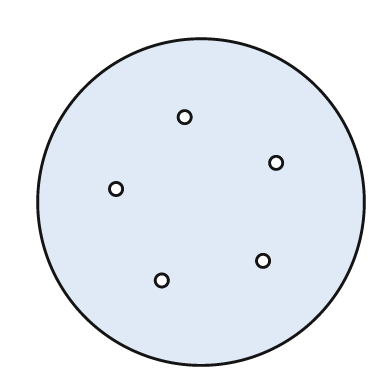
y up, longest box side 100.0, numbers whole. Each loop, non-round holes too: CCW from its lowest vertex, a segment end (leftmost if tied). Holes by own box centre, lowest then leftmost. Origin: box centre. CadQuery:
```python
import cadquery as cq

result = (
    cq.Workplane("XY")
    .moveTo(0.0, 0.0)
    .circle(50.0)
    .moveTo(-12.0, -24.0)
    .circle(2.0)
    .moveTo(19.0, -18.0)
    .circle(2.0)
    .moveTo(-26.0, 4.0)
    .circle(2.0)
    .moveTo(23.0, 12.0)
    .circle(2.0)
    .moveTo(-5.0, 26.0)
    .circle(2.0)
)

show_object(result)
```